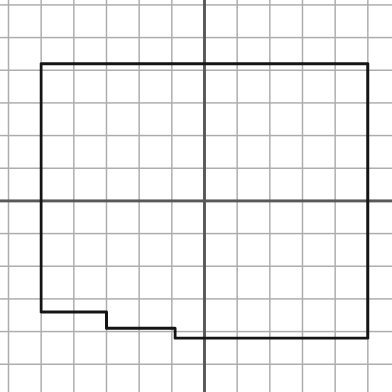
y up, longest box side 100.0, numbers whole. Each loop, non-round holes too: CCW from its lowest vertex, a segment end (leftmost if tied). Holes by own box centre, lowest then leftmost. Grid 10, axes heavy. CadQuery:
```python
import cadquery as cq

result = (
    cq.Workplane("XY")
    .moveTo(-9.0, -42.0)
    .lineTo(50.0, -42.0)
    .lineTo(50.0, 42.0)
    .lineTo(-50.0, 42.0)
    .lineTo(-50.0, -34.0)
    .lineTo(-30.0, -34.0)
    .lineTo(-30.0, -39.0)
    .lineTo(-9.0, -39.0)
    .close()
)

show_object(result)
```